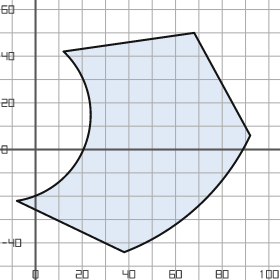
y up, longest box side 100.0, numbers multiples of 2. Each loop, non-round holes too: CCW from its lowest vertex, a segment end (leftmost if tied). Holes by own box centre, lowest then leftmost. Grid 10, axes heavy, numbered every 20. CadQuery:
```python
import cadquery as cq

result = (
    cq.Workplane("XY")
    .moveTo(38.0, -44.0)
    .threePointArc((70.0, -24.0), (92.0, 6.0))
    .lineTo(68.0, 50.0)
    .lineTo(12.0, 42.0)
    .threePointArc((22.0, 4.0), (-8.0, -22.0))
    .close()
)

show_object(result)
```